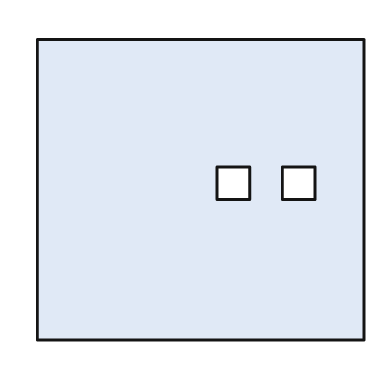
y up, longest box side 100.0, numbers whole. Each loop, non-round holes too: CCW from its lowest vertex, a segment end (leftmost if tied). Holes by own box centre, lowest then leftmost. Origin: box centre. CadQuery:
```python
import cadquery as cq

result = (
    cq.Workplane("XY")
    .moveTo(-50.0, -46.0)
    .lineTo(50.0, -46.0)
    .lineTo(50.0, 46.0)
    .lineTo(-50.0, 46.0)
    .close()
    .moveTo(5.0, -3.0)
    .lineTo(15.0, -3.0)
    .lineTo(15.0, 7.0)
    .lineTo(5.0, 7.0)
    .close()
    .moveTo(25.0, -3.0)
    .lineTo(35.0, -3.0)
    .lineTo(35.0, 7.0)
    .lineTo(25.0, 7.0)
    .close()
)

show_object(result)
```